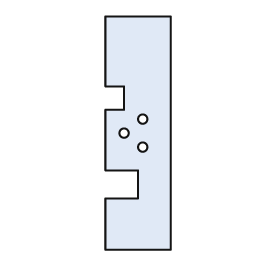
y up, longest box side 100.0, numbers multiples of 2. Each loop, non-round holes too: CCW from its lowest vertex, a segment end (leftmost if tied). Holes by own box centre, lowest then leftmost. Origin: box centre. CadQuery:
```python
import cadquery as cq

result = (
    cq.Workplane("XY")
    .moveTo(-14.0, -50.0)
    .lineTo(14.0, -50.0)
    .lineTo(14.0, 50.0)
    .lineTo(-14.0, 50.0)
    .lineTo(-14.0, 20.0)
    .lineTo(-6.0, 20.0)
    .lineTo(-6.0, 10.0)
    .lineTo(-14.0, 10.0)
    .lineTo(-14.0, -16.0)
    .lineTo(0.0, -16.0)
    .lineTo(0.0, -28.0)
    .lineTo(-14.0, -28.0)
    .close()
    .moveTo(2.0, -6.0)
    .circle(2.0)
    .moveTo(-6.0, 0.0)
    .circle(2.0)
    .moveTo(2.0, 6.0)
    .circle(2.0)
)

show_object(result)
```